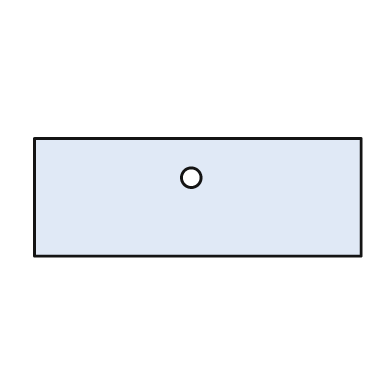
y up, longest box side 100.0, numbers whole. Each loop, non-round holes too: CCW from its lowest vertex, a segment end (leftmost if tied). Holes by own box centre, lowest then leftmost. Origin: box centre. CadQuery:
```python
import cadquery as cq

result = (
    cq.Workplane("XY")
    .moveTo(-50.0, -18.0)
    .lineTo(50.0, -18.0)
    .lineTo(50.0, 18.0)
    .lineTo(-50.0, 18.0)
    .close()
    .moveTo(-2.0, 6.0)
    .circle(3.0)
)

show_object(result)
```